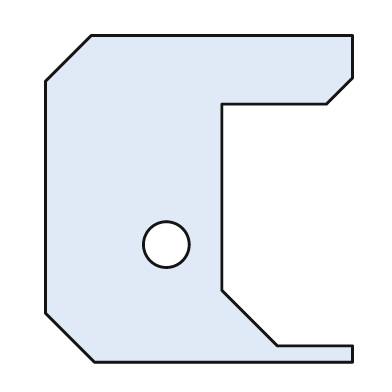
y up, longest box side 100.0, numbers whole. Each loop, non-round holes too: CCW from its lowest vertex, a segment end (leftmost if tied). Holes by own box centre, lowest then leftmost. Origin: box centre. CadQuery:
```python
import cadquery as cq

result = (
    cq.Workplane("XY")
    .moveTo(-32.0, -50.0)
    .lineTo(47.0, -50.0)
    .lineTo(47.0, -45.0)
    .lineTo(24.0, -45.0)
    .lineTo(7.0, -28.0)
    .lineTo(7.0, 29.0)
    .lineTo(39.0, 29.0)
    .lineTo(47.0, 37.0)
    .lineTo(47.0, 50.0)
    .lineTo(-33.0, 50.0)
    .lineTo(-47.0, 36.0)
    .lineTo(-47.0, -35.0)
    .close()
    .moveTo(-10.0, -14.0)
    .circle(7.0)
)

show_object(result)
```